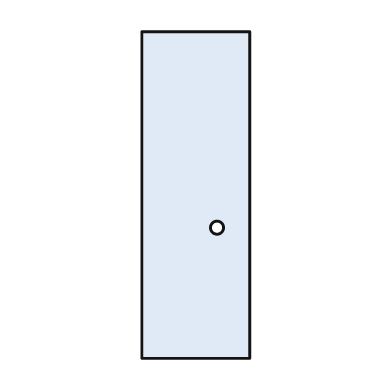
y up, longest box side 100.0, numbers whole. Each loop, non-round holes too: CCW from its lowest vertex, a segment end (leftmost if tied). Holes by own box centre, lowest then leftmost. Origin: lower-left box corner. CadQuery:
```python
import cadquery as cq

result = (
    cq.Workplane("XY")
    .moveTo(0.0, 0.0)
    .lineTo(33.0, 0.0)
    .lineTo(33.0, 100.0)
    .lineTo(0.0, 100.0)
    .close()
    .moveTo(23.0, 40.0)
    .circle(2.0)
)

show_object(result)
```